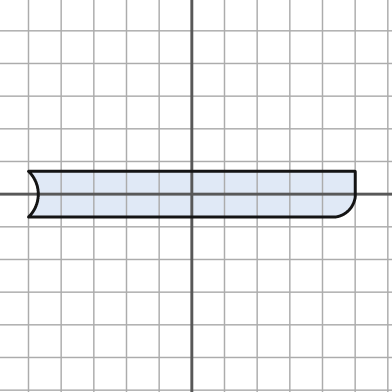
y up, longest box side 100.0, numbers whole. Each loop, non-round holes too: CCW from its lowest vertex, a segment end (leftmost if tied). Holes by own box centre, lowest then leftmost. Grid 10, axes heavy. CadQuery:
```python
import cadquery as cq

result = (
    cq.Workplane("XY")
    .moveTo(-50.0, -7.0)
    .lineTo(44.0, -7.0)
    .threePointArc((48.0, -5.0), (50.0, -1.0))
    .lineTo(50.0, 7.0)
    .lineTo(-50.0, 7.0)
    .threePointArc((-47.0, 0.0), (-50.0, -7.0))
    .close()
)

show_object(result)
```